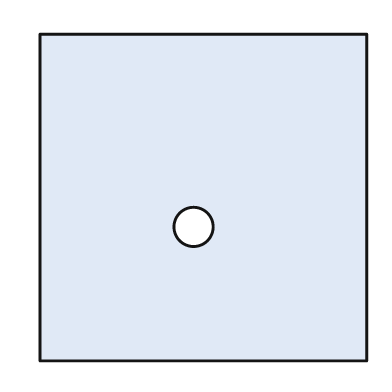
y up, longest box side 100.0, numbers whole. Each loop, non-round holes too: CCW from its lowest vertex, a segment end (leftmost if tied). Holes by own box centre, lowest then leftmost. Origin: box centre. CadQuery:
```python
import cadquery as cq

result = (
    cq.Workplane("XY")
    .moveTo(-50.0, -50.0)
    .lineTo(50.0, -50.0)
    .lineTo(50.0, 50.0)
    .lineTo(-50.0, 50.0)
    .close()
    .moveTo(-3.0, -9.0)
    .circle(6.0)
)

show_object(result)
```